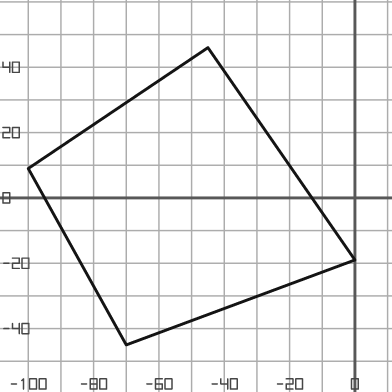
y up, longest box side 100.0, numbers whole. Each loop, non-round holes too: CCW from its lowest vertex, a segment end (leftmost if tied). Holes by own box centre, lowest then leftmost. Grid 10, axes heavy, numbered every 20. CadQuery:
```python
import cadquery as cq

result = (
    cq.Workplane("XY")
    .moveTo(-70.0, -45.0)
    .lineTo(0.0, -19.0)
    .lineTo(-45.0, 46.0)
    .lineTo(-100.0, 9.0)
    .close()
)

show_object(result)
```